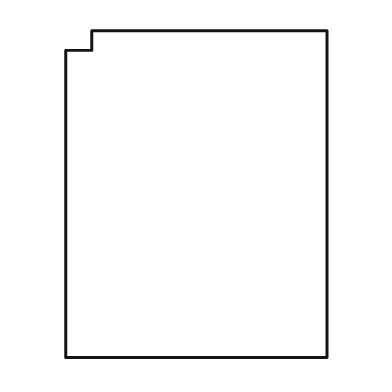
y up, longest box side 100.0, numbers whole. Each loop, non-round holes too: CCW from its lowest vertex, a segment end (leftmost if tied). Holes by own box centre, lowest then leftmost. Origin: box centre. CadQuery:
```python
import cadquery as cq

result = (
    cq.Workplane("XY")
    .moveTo(-40.0, -50.0)
    .lineTo(40.0, -50.0)
    .lineTo(40.0, 50.0)
    .lineTo(-32.0, 50.0)
    .lineTo(-32.0, 44.0)
    .lineTo(-40.0, 44.0)
    .close()
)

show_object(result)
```